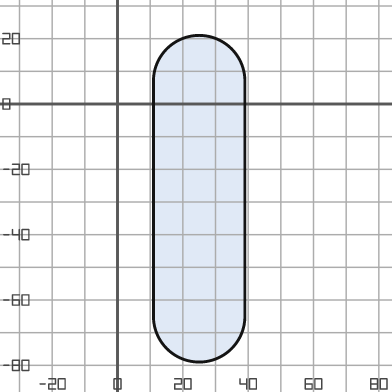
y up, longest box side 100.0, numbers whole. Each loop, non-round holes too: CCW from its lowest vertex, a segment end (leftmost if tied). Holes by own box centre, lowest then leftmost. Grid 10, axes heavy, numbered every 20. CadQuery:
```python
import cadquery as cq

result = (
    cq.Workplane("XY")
    .moveTo(11.0, -65.0)
    .threePointArc((25.0, -79.0), (39.0, -65.0))
    .lineTo(39.0, 7.0)
    .threePointArc((25.0, 21.0), (11.0, 7.0))
    .close()
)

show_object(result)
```